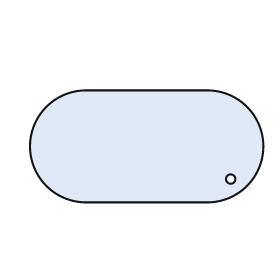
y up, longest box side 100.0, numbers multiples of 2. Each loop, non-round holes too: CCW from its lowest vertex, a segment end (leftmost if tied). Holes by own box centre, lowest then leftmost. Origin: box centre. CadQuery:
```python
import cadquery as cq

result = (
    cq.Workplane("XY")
    .moveTo(-26.0, -24.0)
    .lineTo(26.0, -24.0)
    .threePointArc((50.0, 0.0), (26.0, 24.0))
    .lineTo(-26.0, 24.0)
    .threePointArc((-50.0, 0.0), (-26.0, -24.0))
    .close()
    .moveTo(36.0, -14.0)
    .circle(2.0)
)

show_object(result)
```